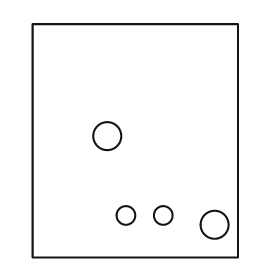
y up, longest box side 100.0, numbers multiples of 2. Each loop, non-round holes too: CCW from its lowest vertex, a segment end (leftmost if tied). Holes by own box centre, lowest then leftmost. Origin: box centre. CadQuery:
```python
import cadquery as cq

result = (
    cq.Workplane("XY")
    .moveTo(-44.0, -50.0)
    .lineTo(44.0, -50.0)
    .lineTo(44.0, 50.0)
    .lineTo(-44.0, 50.0)
    .close()
    .moveTo(34.0, -36.0)
    .circle(6.0)
    .moveTo(-4.0, -32.0)
    .circle(4.0)
    .moveTo(12.0, -32.0)
    .circle(4.0)
    .moveTo(-12.0, 2.0)
    .circle(6.0)
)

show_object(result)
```